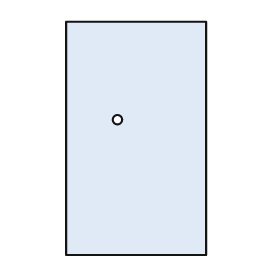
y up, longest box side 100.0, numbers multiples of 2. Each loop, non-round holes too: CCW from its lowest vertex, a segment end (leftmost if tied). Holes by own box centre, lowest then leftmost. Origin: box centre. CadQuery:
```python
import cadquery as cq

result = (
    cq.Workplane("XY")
    .moveTo(-30.0, -50.0)
    .lineTo(30.0, -50.0)
    .lineTo(30.0, 50.0)
    .lineTo(-30.0, 50.0)
    .close()
    .moveTo(-8.0, 8.0)
    .circle(2.0)
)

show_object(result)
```